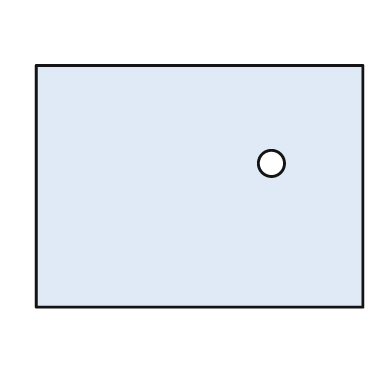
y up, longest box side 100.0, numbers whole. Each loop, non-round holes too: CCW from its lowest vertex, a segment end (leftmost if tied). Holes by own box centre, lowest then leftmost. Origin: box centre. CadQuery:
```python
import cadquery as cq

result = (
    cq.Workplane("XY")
    .moveTo(-50.0, -37.0)
    .lineTo(50.0, -37.0)
    .lineTo(50.0, 37.0)
    .lineTo(-50.0, 37.0)
    .close()
    .moveTo(22.0, 7.0)
    .circle(4.0)
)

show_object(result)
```